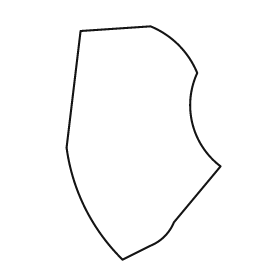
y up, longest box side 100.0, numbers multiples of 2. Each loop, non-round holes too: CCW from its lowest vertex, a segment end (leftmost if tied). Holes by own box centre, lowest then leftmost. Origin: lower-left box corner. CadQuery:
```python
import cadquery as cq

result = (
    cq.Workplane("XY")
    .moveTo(24.0, 0.0)
    .lineTo(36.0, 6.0)
    .threePointArc((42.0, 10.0), (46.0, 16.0))
    .lineTo(66.0, 40.0)
    .threePointArc((54.0, 58.0), (56.0, 80.0))
    .threePointArc((48.0, 92.0), (36.0, 100.0))
    .lineTo(6.0, 98.0)
    .lineTo(0.0, 48.0)
    .threePointArc((8.0, 22.0), (24.0, 0.0))
    .close()
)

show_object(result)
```